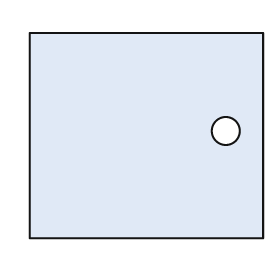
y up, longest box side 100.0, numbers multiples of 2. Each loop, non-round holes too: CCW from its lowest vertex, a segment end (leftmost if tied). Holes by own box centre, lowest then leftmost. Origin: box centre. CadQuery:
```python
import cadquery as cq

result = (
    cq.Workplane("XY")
    .moveTo(-50.0, -44.0)
    .lineTo(50.0, -44.0)
    .lineTo(50.0, 44.0)
    .lineTo(-50.0, 44.0)
    .close()
    .moveTo(34.0, 2.0)
    .circle(6.0)
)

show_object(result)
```